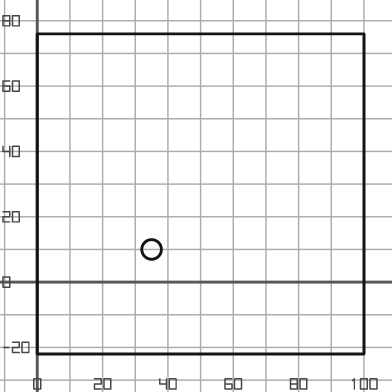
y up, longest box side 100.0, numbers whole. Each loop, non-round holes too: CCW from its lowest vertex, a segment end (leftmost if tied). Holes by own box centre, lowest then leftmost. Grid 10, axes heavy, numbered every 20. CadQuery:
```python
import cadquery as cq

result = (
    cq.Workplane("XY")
    .moveTo(0.0, -22.0)
    .lineTo(100.0, -22.0)
    .lineTo(100.0, 76.0)
    .lineTo(0.0, 76.0)
    .close()
    .moveTo(35.0, 10.0)
    .circle(3.0)
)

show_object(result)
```